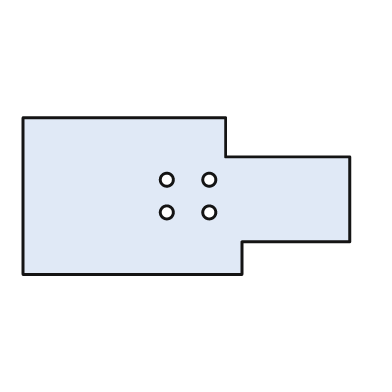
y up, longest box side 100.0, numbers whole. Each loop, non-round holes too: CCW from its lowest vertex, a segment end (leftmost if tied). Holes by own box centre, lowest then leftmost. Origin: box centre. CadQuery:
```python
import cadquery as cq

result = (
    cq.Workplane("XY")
    .moveTo(-50.0, -24.0)
    .lineTo(17.0, -24.0)
    .lineTo(17.0, -14.0)
    .lineTo(50.0, -14.0)
    .lineTo(50.0, 12.0)
    .lineTo(12.0, 12.0)
    .lineTo(12.0, 24.0)
    .lineTo(-50.0, 24.0)
    .close()
    .moveTo(-6.0, -5.0)
    .circle(2.0)
    .moveTo(7.0, -5.0)
    .circle(2.0)
    .moveTo(-6.0, 5.0)
    .circle(2.0)
    .moveTo(7.0, 5.0)
    .circle(2.0)
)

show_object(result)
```